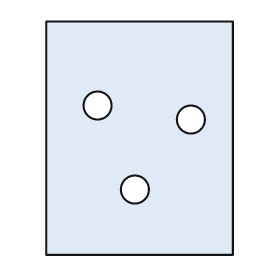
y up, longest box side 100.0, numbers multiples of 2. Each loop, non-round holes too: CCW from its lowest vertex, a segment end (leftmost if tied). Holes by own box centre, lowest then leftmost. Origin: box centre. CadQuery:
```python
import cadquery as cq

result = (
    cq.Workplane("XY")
    .moveTo(-40.0, -50.0)
    .lineTo(40.0, -50.0)
    .lineTo(40.0, 50.0)
    .lineTo(-40.0, 50.0)
    .close()
    .moveTo(-2.0, -22.0)
    .circle(6.0)
    .moveTo(22.0, 8.0)
    .circle(6.0)
    .moveTo(-18.0, 14.0)
    .circle(6.0)
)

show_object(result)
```